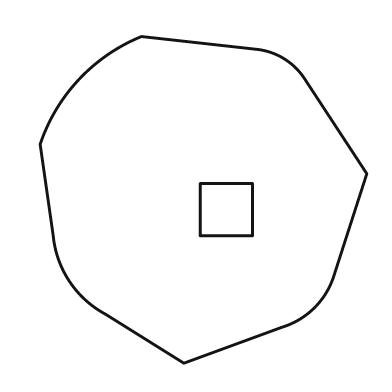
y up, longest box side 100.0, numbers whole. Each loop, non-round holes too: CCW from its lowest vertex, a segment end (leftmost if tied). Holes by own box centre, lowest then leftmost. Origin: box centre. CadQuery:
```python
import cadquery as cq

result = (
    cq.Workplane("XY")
    .moveTo(-6.0, -50.0)
    .lineTo(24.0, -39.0)
    .threePointArc((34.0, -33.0), (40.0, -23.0))
    .lineTo(50.0, 8.0)
    .lineTo(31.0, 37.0)
    .threePointArc((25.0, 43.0), (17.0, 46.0))
    .lineTo(-19.0, 50.0)
    .threePointArc((-38.0, 37.0), (-50.0, 17.0))
    .lineTo(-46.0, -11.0)
    .threePointArc((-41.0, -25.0), (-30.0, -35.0))
    .close()
    .moveTo(-1.0, -11.0)
    .lineTo(15.0, -11.0)
    .lineTo(15.0, 5.0)
    .lineTo(-1.0, 5.0)
    .close()
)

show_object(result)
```